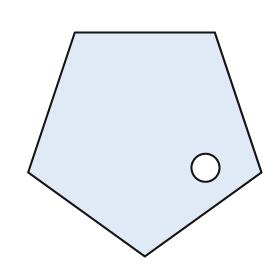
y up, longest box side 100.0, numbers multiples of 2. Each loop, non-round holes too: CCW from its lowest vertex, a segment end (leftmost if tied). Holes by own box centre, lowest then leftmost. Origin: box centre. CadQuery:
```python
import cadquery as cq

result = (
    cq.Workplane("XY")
    .moveTo(0.0, -48.0)
    .lineTo(50.0, -12.0)
    .lineTo(30.0, 48.0)
    .lineTo(-30.0, 48.0)
    .lineTo(-50.0, -12.0)
    .close()
    .moveTo(26.0, -10.0)
    .circle(6.0)
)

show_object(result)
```